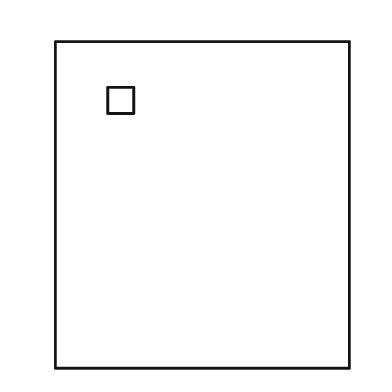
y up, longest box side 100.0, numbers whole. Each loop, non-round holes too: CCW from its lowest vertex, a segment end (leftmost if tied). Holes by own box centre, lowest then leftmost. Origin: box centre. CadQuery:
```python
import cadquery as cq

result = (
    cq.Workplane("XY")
    .moveTo(-45.0, -50.0)
    .lineTo(45.0, -50.0)
    .lineTo(45.0, 50.0)
    .lineTo(-45.0, 50.0)
    .close()
    .moveTo(-29.0, 28.0)
    .lineTo(-21.0, 28.0)
    .lineTo(-21.0, 36.0)
    .lineTo(-29.0, 36.0)
    .close()
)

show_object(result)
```